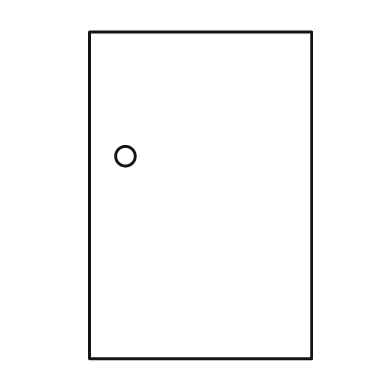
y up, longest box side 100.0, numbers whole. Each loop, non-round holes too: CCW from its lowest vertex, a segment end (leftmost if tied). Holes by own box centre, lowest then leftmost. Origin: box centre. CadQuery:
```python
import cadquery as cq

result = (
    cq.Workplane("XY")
    .moveTo(-34.0, -50.0)
    .lineTo(34.0, -50.0)
    .lineTo(34.0, 50.0)
    .lineTo(-34.0, 50.0)
    .close()
    .moveTo(-23.0, 12.0)
    .circle(3.0)
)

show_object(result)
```